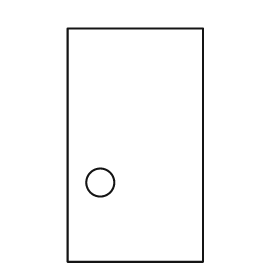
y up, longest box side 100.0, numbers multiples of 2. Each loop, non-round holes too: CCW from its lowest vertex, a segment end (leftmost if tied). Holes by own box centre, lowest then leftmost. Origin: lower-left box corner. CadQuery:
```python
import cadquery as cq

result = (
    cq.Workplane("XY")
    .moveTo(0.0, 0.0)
    .lineTo(58.0, 0.0)
    .lineTo(58.0, 100.0)
    .lineTo(0.0, 100.0)
    .close()
    .moveTo(14.0, 34.0)
    .circle(6.0)
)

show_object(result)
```